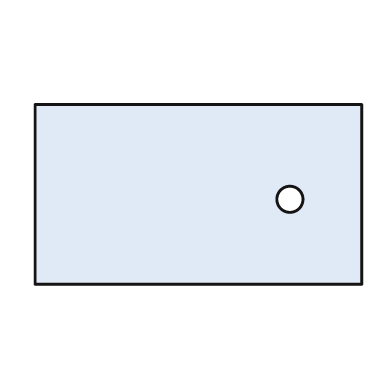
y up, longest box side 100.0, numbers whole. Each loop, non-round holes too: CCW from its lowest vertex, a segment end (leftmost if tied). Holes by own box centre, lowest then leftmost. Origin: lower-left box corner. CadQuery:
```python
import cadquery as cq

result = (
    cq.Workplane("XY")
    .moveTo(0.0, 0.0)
    .lineTo(100.0, 0.0)
    .lineTo(100.0, 55.0)
    .lineTo(0.0, 55.0)
    .close()
    .moveTo(78.0, 26.0)
    .circle(4.0)
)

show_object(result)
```